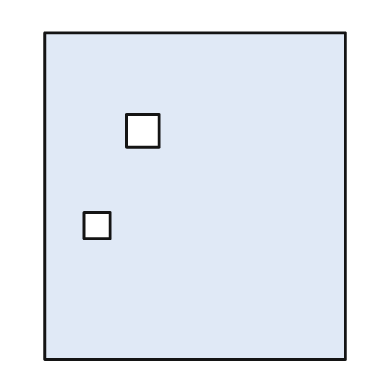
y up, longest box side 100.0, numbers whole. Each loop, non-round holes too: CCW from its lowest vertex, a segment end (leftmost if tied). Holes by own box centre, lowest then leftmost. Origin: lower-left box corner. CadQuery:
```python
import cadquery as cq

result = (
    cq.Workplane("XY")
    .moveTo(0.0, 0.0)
    .lineTo(92.0, 0.0)
    .lineTo(92.0, 100.0)
    .lineTo(0.0, 100.0)
    .close()
    .moveTo(12.0, 37.0)
    .lineTo(20.0, 37.0)
    .lineTo(20.0, 45.0)
    .lineTo(12.0, 45.0)
    .close()
    .moveTo(25.0, 65.0)
    .lineTo(35.0, 65.0)
    .lineTo(35.0, 75.0)
    .lineTo(25.0, 75.0)
    .close()
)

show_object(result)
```